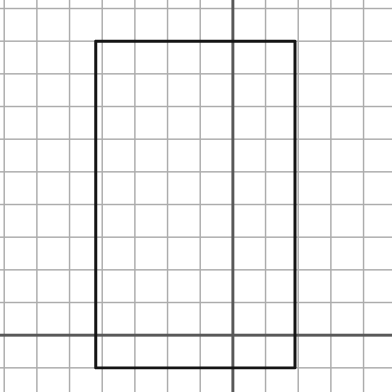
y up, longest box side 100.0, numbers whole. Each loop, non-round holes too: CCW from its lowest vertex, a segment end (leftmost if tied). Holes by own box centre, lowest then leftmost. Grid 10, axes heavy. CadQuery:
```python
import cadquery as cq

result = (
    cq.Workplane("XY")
    .moveTo(-42.0, -10.0)
    .lineTo(19.0, -10.0)
    .lineTo(19.0, 90.0)
    .lineTo(-42.0, 90.0)
    .close()
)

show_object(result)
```